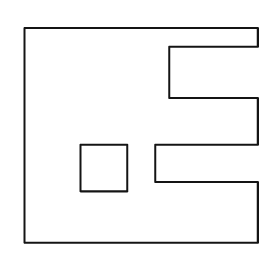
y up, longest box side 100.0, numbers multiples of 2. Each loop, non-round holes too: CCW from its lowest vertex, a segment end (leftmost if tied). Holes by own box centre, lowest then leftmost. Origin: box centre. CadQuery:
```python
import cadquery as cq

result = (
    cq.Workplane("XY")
    .moveTo(-50.0, -46.0)
    .lineTo(50.0, -46.0)
    .lineTo(50.0, -20.0)
    .lineTo(6.0, -20.0)
    .lineTo(6.0, -4.0)
    .lineTo(50.0, -4.0)
    .lineTo(50.0, 16.0)
    .lineTo(12.0, 16.0)
    .lineTo(12.0, 38.0)
    .lineTo(50.0, 38.0)
    .lineTo(50.0, 46.0)
    .lineTo(-50.0, 46.0)
    .close()
    .moveTo(-26.0, -24.0)
    .lineTo(-6.0, -24.0)
    .lineTo(-6.0, -4.0)
    .lineTo(-26.0, -4.0)
    .close()
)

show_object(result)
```